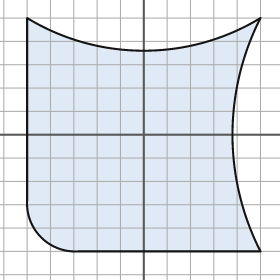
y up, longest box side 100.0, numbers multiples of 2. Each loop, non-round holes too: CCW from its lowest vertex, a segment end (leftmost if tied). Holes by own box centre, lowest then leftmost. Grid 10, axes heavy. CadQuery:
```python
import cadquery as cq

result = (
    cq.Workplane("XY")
    .moveTo(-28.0, -50.0)
    .lineTo(50.0, -50.0)
    .threePointArc((38.0, 0.0), (50.0, 50.0))
    .threePointArc((0.0, 36.0), (-50.0, 50.0))
    .lineTo(-50.0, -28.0)
    .threePointArc((-44.0, -44.0), (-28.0, -50.0))
    .close()
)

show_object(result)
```